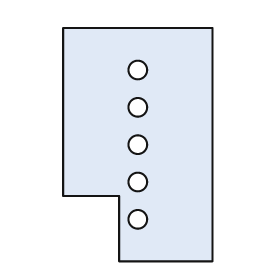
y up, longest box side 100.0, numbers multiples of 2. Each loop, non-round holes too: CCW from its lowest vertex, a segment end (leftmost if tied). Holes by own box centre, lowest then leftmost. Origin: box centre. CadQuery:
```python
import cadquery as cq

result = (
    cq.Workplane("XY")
    .moveTo(-8.0, -50.0)
    .lineTo(32.0, -50.0)
    .lineTo(32.0, 50.0)
    .lineTo(-32.0, 50.0)
    .lineTo(-32.0, -22.0)
    .lineTo(-8.0, -22.0)
    .close()
    .moveTo(0.0, -32.0)
    .circle(4.0)
    .moveTo(0.0, -16.0)
    .circle(4.0)
    .moveTo(0.0, 0.0)
    .circle(4.0)
    .moveTo(0.0, 16.0)
    .circle(4.0)
    .moveTo(0.0, 32.0)
    .circle(4.0)
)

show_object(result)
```